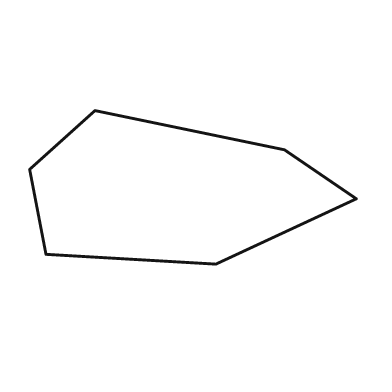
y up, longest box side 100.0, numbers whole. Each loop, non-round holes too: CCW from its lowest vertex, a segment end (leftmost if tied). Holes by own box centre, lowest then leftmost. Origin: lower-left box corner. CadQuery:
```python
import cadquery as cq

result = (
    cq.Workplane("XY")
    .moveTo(57.0, 0.0)
    .lineTo(100.0, 20.0)
    .lineTo(78.0, 35.0)
    .lineTo(20.0, 47.0)
    .lineTo(0.0, 29.0)
    .lineTo(5.0, 3.0)
    .close()
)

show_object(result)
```